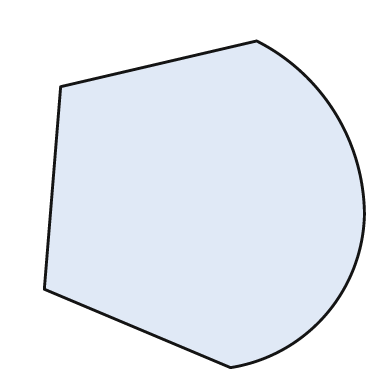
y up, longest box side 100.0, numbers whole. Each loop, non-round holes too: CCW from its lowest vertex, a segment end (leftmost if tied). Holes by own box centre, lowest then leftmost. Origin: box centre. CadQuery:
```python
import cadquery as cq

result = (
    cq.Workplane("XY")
    .moveTo(8.0, -50.0)
    .threePointArc((37.0, -34.0), (49.0, -3.0))
    .threePointArc((40.0, 28.0), (16.0, 50.0))
    .lineTo(-44.0, 36.0)
    .lineTo(-49.0, -26.0)
    .close()
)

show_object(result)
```